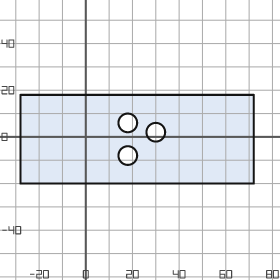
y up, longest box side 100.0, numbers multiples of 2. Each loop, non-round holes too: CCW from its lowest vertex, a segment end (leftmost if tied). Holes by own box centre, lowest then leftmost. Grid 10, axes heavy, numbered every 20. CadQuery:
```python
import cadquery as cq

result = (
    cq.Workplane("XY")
    .moveTo(-28.0, -20.0)
    .lineTo(72.0, -20.0)
    .lineTo(72.0, 18.0)
    .lineTo(-28.0, 18.0)
    .close()
    .moveTo(18.0, -8.0)
    .circle(4.0)
    .moveTo(30.0, 2.0)
    .circle(4.0)
    .moveTo(18.0, 6.0)
    .circle(4.0)
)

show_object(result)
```